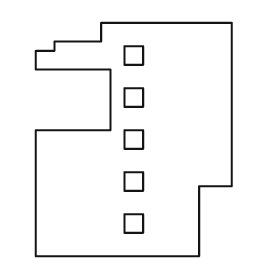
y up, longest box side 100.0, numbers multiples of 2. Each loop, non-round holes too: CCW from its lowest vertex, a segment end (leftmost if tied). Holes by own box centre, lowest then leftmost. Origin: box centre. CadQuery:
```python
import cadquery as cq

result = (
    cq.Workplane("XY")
    .moveTo(-42.0, -50.0)
    .lineTo(28.0, -50.0)
    .lineTo(28.0, -20.0)
    .lineTo(42.0, -20.0)
    .lineTo(42.0, 50.0)
    .lineTo(-14.0, 50.0)
    .lineTo(-14.0, 42.0)
    .lineTo(-34.0, 42.0)
    .lineTo(-34.0, 38.0)
    .lineTo(-42.0, 38.0)
    .lineTo(-42.0, 30.0)
    .lineTo(-10.0, 30.0)
    .lineTo(-10.0, 4.0)
    .lineTo(-42.0, 4.0)
    .close()
    .moveTo(-4.0, -40.0)
    .lineTo(4.0, -40.0)
    .lineTo(4.0, -32.0)
    .lineTo(-4.0, -32.0)
    .close()
    .moveTo(-4.0, -22.0)
    .lineTo(4.0, -22.0)
    .lineTo(4.0, -14.0)
    .lineTo(-4.0, -14.0)
    .close()
    .moveTo(-4.0, -4.0)
    .lineTo(4.0, -4.0)
    .lineTo(4.0, 4.0)
    .lineTo(-4.0, 4.0)
    .close()
    .moveTo(-4.0, 14.0)
    .lineTo(4.0, 14.0)
    .lineTo(4.0, 22.0)
    .lineTo(-4.0, 22.0)
    .close()
    .moveTo(-4.0, 32.0)
    .lineTo(4.0, 32.0)
    .lineTo(4.0, 40.0)
    .lineTo(-4.0, 40.0)
    .close()
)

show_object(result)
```